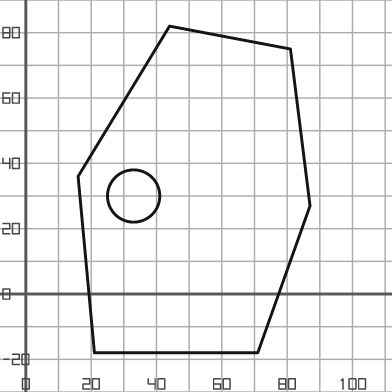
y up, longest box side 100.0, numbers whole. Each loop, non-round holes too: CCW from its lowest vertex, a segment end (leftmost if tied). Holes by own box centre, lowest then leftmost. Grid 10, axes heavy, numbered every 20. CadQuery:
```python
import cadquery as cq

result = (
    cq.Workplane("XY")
    .moveTo(21.0, -18.0)
    .lineTo(71.0, -18.0)
    .lineTo(87.0, 27.0)
    .lineTo(81.0, 75.0)
    .lineTo(44.0, 82.0)
    .lineTo(16.0, 36.0)
    .close()
    .moveTo(33.0, 30.0)
    .circle(8.0)
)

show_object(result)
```